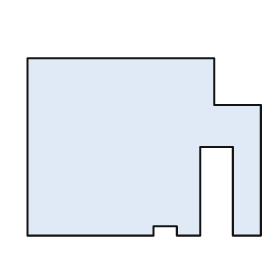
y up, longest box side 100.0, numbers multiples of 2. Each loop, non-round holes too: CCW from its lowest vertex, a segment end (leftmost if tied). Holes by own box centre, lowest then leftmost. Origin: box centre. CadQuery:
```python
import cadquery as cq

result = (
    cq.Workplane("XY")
    .moveTo(-50.0, -38.0)
    .lineTo(4.0, -38.0)
    .lineTo(4.0, -34.0)
    .lineTo(14.0, -34.0)
    .lineTo(14.0, -38.0)
    .lineTo(24.0, -38.0)
    .lineTo(24.0, 0.0)
    .lineTo(38.0, 0.0)
    .lineTo(38.0, -38.0)
    .lineTo(50.0, -38.0)
    .lineTo(50.0, 18.0)
    .lineTo(30.0, 18.0)
    .lineTo(30.0, 38.0)
    .lineTo(-50.0, 38.0)
    .close()
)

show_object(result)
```